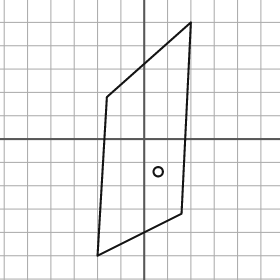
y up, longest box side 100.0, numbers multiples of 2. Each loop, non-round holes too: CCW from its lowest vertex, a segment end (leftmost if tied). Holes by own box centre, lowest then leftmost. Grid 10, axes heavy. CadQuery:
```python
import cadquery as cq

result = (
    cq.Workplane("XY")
    .moveTo(-20.0, -50.0)
    .lineTo(16.0, -32.0)
    .lineTo(20.0, 50.0)
    .lineTo(-16.0, 18.0)
    .close()
    .moveTo(6.0, -14.0)
    .circle(2.0)
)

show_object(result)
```